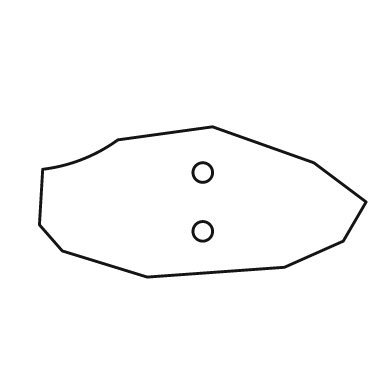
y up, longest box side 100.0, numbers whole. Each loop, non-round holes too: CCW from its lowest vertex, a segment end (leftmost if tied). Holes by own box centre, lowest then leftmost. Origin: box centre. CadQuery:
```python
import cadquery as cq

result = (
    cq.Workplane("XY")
    .moveTo(-17.0, -23.0)
    .lineTo(25.0, -20.0)
    .lineTo(43.0, -12.0)
    .lineTo(50.0, 0.0)
    .lineTo(34.0, 12.0)
    .lineTo(3.0, 23.0)
    .lineTo(-26.0, 19.0)
    .threePointArc((-37.0, 13.0), (-49.0, 10.0))
    .lineTo(-50.0, -7.0)
    .lineTo(-43.0, -15.0)
    .close()
    .moveTo(0.0, -9.0)
    .circle(3.0)
    .moveTo(0.0, 9.0)
    .circle(3.0)
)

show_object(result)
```